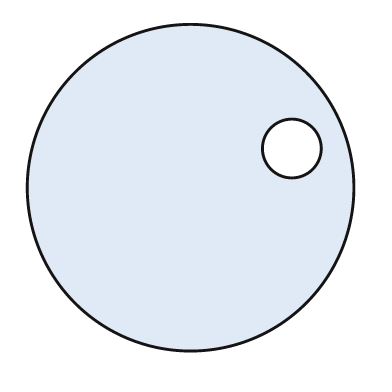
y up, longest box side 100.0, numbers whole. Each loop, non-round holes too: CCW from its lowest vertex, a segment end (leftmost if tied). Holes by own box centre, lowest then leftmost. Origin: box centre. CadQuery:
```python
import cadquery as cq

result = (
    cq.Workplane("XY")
    .moveTo(0.0, 0.0)
    .circle(50.0)
    .moveTo(31.0, 12.0)
    .circle(9.0)
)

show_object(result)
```